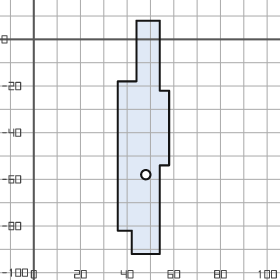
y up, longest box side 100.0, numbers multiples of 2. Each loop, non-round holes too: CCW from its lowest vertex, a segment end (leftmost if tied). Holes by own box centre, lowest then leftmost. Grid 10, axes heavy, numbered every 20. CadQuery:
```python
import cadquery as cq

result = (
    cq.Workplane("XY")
    .moveTo(42.0, -92.0)
    .lineTo(54.0, -92.0)
    .lineTo(54.0, -54.0)
    .lineTo(58.0, -54.0)
    .lineTo(58.0, -22.0)
    .lineTo(54.0, -22.0)
    .lineTo(54.0, 8.0)
    .lineTo(44.0, 8.0)
    .lineTo(44.0, -18.0)
    .lineTo(36.0, -18.0)
    .lineTo(36.0, -82.0)
    .lineTo(42.0, -82.0)
    .close()
    .moveTo(48.0, -58.0)
    .circle(2.0)
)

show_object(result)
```